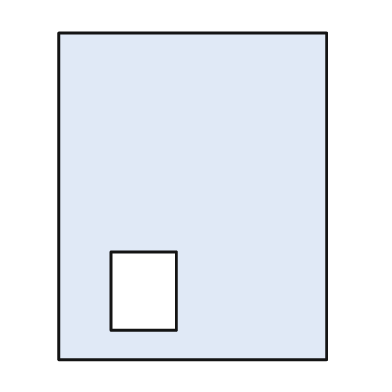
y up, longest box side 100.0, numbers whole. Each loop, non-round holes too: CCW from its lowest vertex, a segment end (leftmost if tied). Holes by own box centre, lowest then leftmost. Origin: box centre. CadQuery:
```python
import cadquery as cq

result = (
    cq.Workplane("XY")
    .moveTo(-41.0, -50.0)
    .lineTo(41.0, -50.0)
    .lineTo(41.0, 50.0)
    .lineTo(-41.0, 50.0)
    .close()
    .moveTo(-25.0, -41.0)
    .lineTo(-5.0, -41.0)
    .lineTo(-5.0, -17.0)
    .lineTo(-25.0, -17.0)
    .close()
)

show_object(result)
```